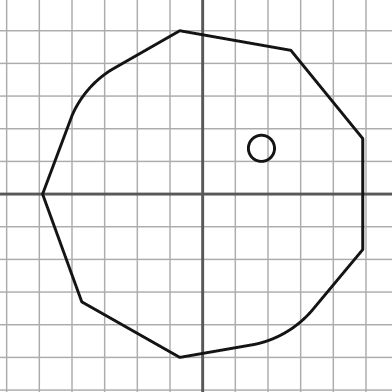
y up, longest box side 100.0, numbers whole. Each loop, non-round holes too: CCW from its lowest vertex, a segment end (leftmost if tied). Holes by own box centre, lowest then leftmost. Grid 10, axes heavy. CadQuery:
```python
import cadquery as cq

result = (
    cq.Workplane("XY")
    .moveTo(-7.0, -50.0)
    .lineTo(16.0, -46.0)
    .threePointArc((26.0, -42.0), (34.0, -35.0))
    .lineTo(49.0, -17.0)
    .lineTo(49.0, 17.0)
    .lineTo(27.0, 44.0)
    .lineTo(-7.0, 50.0)
    .lineTo(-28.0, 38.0)
    .threePointArc((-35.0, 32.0), (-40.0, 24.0))
    .lineTo(-49.0, 0.0)
    .lineTo(-37.0, -33.0)
    .close()
    .moveTo(18.0, 14.0)
    .circle(4.0)
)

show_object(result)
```